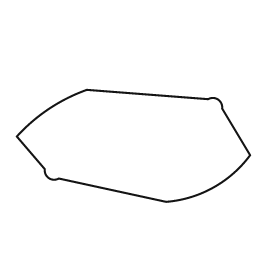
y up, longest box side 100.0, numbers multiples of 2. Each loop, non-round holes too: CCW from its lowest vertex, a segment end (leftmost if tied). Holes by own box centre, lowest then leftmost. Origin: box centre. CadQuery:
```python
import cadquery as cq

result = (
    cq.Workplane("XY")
    .moveTo(14.0, -24.0)
    .threePointArc((34.0, -18.0), (50.0, -4.0))
    .lineTo(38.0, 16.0)
    .threePointArc((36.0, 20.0), (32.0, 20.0))
    .lineTo(-20.0, 24.0)
    .threePointArc((-36.0, 16.0), (-50.0, 4.0))
    .lineTo(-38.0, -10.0)
    .threePointArc((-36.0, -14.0), (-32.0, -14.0))
    .close()
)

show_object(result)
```